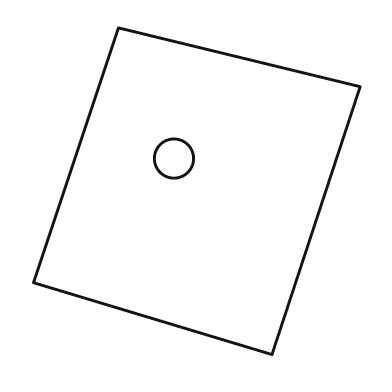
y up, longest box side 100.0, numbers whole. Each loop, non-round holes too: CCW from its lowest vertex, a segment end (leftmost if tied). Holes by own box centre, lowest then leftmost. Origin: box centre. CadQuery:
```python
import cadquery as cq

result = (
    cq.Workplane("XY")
    .moveTo(23.0, -50.0)
    .lineTo(50.0, 32.0)
    .lineTo(-24.0, 50.0)
    .lineTo(-50.0, -28.0)
    .close()
    .moveTo(-7.0, 10.0)
    .circle(6.0)
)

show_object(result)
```